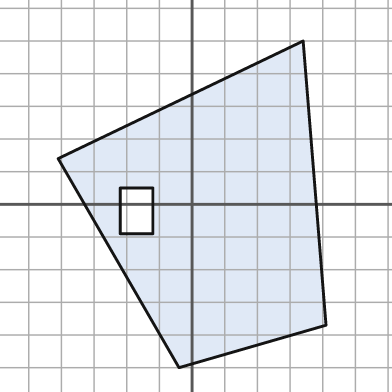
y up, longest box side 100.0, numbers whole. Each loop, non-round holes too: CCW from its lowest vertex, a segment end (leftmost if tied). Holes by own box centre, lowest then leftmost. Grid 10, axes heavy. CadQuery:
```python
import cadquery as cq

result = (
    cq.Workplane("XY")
    .moveTo(-4.0, -50.0)
    .lineTo(41.0, -37.0)
    .lineTo(34.0, 50.0)
    .lineTo(-41.0, 14.0)
    .close()
    .moveTo(-22.0, -9.0)
    .lineTo(-12.0, -9.0)
    .lineTo(-12.0, 5.0)
    .lineTo(-22.0, 5.0)
    .close()
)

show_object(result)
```